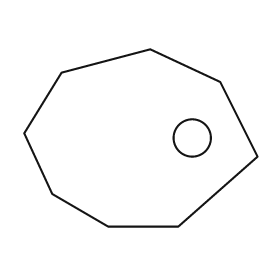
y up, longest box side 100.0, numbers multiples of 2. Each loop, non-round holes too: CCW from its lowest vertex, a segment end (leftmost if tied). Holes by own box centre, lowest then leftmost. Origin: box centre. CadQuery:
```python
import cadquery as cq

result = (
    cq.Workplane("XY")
    .moveTo(-14.0, -38.0)
    .lineTo(16.0, -38.0)
    .lineTo(50.0, -8.0)
    .lineTo(34.0, 24.0)
    .lineTo(4.0, 38.0)
    .lineTo(-34.0, 28.0)
    .lineTo(-50.0, 2.0)
    .lineTo(-38.0, -24.0)
    .close()
    .moveTo(22.0, 0.0)
    .circle(8.0)
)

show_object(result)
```